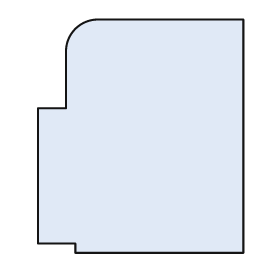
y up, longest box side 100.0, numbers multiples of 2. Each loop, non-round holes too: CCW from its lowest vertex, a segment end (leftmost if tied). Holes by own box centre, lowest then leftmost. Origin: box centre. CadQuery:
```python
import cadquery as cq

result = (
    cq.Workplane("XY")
    .moveTo(-28.0, -50.0)
    .lineTo(44.0, -50.0)
    .lineTo(44.0, 50.0)
    .lineTo(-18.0, 50.0)
    .threePointArc((-28.0, 46.0), (-32.0, 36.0))
    .lineTo(-32.0, 12.0)
    .lineTo(-44.0, 12.0)
    .lineTo(-44.0, -46.0)
    .lineTo(-28.0, -46.0)
    .close()
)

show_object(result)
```